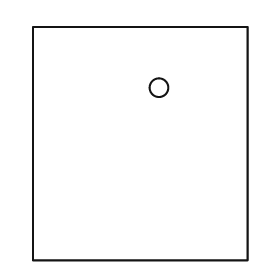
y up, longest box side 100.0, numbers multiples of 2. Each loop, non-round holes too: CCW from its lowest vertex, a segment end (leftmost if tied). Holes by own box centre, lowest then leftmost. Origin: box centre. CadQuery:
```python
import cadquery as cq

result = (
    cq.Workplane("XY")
    .moveTo(-46.0, -50.0)
    .lineTo(46.0, -50.0)
    .lineTo(46.0, 50.0)
    .lineTo(-46.0, 50.0)
    .close()
    .moveTo(8.0, 24.0)
    .circle(4.0)
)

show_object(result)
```